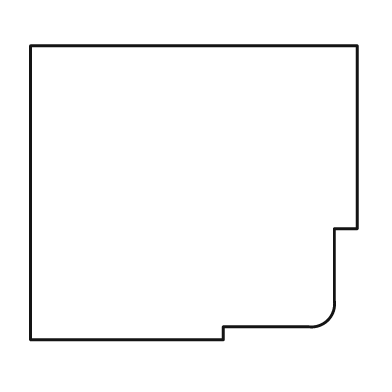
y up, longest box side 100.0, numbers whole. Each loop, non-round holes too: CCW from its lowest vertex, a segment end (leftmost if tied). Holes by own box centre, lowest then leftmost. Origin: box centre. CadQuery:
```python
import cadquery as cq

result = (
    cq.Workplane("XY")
    .moveTo(-50.0, -45.0)
    .lineTo(9.0, -45.0)
    .lineTo(9.0, -41.0)
    .lineTo(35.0, -41.0)
    .threePointArc((41.0, -39.0), (43.0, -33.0))
    .lineTo(43.0, -11.0)
    .lineTo(50.0, -11.0)
    .lineTo(50.0, 45.0)
    .lineTo(-50.0, 45.0)
    .close()
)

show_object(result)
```